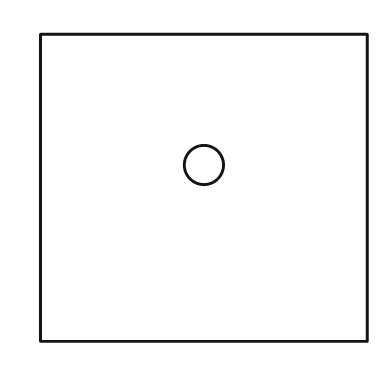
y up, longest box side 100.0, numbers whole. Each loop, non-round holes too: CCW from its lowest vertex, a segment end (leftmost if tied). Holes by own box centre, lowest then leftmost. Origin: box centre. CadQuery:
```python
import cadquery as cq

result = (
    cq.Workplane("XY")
    .moveTo(-50.0, -47.0)
    .lineTo(50.0, -47.0)
    .lineTo(50.0, 47.0)
    .lineTo(-50.0, 47.0)
    .close()
    .moveTo(0.0, 7.0)
    .circle(6.0)
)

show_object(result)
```